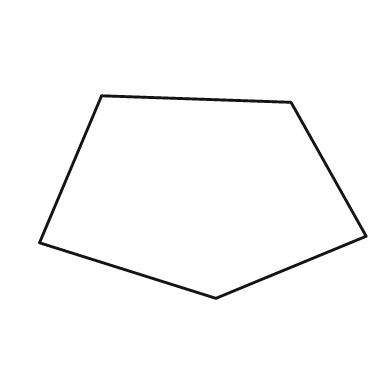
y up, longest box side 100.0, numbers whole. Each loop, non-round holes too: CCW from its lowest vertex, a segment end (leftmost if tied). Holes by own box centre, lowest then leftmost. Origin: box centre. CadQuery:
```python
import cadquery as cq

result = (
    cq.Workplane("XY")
    .moveTo(4.0, -31.0)
    .lineTo(50.0, -12.0)
    .lineTo(27.0, 29.0)
    .lineTo(-31.0, 31.0)
    .lineTo(-50.0, -14.0)
    .close()
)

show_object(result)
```